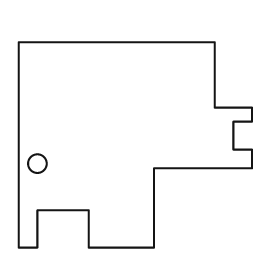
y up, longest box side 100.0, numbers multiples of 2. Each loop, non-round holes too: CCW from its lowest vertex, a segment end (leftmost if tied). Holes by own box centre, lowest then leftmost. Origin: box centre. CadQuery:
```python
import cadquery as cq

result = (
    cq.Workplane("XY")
    .moveTo(-50.0, -44.0)
    .lineTo(-42.0, -44.0)
    .lineTo(-42.0, -28.0)
    .lineTo(-20.0, -28.0)
    .lineTo(-20.0, -44.0)
    .lineTo(8.0, -44.0)
    .lineTo(8.0, -10.0)
    .lineTo(50.0, -10.0)
    .lineTo(50.0, -2.0)
    .lineTo(42.0, -2.0)
    .lineTo(42.0, 10.0)
    .lineTo(50.0, 10.0)
    .lineTo(50.0, 16.0)
    .lineTo(34.0, 16.0)
    .lineTo(34.0, 44.0)
    .lineTo(-50.0, 44.0)
    .close()
    .moveTo(-42.0, -8.0)
    .circle(4.0)
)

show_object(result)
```